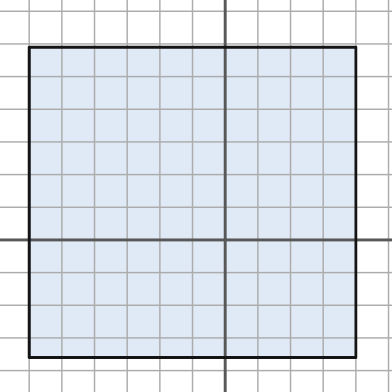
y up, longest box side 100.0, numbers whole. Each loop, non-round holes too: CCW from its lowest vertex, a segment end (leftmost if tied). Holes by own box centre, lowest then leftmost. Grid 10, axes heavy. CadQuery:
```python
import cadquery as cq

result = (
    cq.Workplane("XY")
    .moveTo(-60.0, -36.0)
    .lineTo(40.0, -36.0)
    .lineTo(40.0, 59.0)
    .lineTo(-60.0, 59.0)
    .close()
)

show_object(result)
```